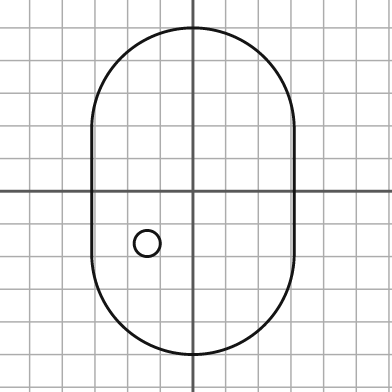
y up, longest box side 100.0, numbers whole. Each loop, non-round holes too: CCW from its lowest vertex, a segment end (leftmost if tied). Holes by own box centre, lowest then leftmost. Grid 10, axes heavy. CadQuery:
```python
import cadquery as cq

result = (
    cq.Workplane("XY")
    .moveTo(-31.0, -19.0)
    .threePointArc((0.0, -50.0), (31.0, -19.0))
    .lineTo(31.0, 19.0)
    .threePointArc((0.0, 50.0), (-31.0, 19.0))
    .close()
    .moveTo(-14.0, -16.0)
    .circle(4.0)
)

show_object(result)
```